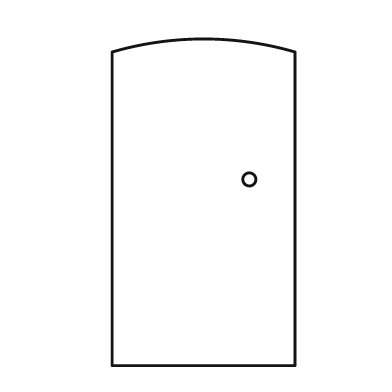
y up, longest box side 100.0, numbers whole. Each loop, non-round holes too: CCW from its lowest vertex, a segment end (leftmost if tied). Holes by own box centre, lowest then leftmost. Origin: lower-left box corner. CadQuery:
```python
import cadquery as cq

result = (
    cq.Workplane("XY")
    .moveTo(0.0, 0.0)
    .lineTo(56.0, 0.0)
    .lineTo(56.0, 96.0)
    .threePointArc((28.0, 100.0), (0.0, 96.0))
    .close()
    .moveTo(42.0, 57.0)
    .circle(2.0)
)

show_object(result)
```